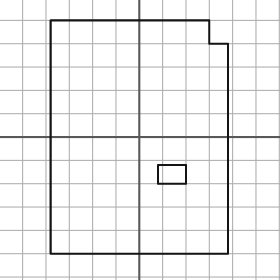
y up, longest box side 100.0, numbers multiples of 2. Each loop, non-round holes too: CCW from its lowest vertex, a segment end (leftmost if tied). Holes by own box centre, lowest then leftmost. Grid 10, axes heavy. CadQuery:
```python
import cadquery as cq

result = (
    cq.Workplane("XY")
    .moveTo(-38.0, -50.0)
    .lineTo(38.0, -50.0)
    .lineTo(38.0, 40.0)
    .lineTo(30.0, 40.0)
    .lineTo(30.0, 50.0)
    .lineTo(-38.0, 50.0)
    .close()
    .moveTo(8.0, -20.0)
    .lineTo(20.0, -20.0)
    .lineTo(20.0, -12.0)
    .lineTo(8.0, -12.0)
    .close()
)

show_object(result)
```